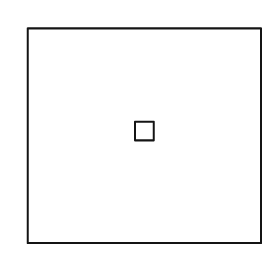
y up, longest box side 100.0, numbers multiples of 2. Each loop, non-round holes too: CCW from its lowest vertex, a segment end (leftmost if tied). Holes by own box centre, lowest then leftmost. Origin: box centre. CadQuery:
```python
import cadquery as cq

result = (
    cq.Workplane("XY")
    .moveTo(-50.0, -46.0)
    .lineTo(50.0, -46.0)
    .lineTo(50.0, 46.0)
    .lineTo(-50.0, 46.0)
    .close()
    .moveTo(-4.0, -2.0)
    .lineTo(4.0, -2.0)
    .lineTo(4.0, 6.0)
    .lineTo(-4.0, 6.0)
    .close()
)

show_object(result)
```